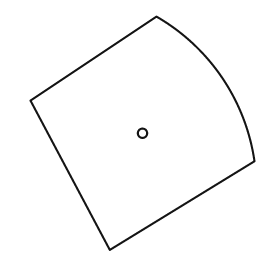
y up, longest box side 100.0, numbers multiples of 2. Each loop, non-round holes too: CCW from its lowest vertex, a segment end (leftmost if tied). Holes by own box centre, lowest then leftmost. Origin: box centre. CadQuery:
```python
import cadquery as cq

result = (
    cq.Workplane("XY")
    .moveTo(-14.0, -50.0)
    .lineTo(48.0, -12.0)
    .threePointArc((34.0, 24.0), (6.0, 50.0))
    .lineTo(-48.0, 14.0)
    .close()
    .moveTo(0.0, 0.0)
    .circle(2.0)
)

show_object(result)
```